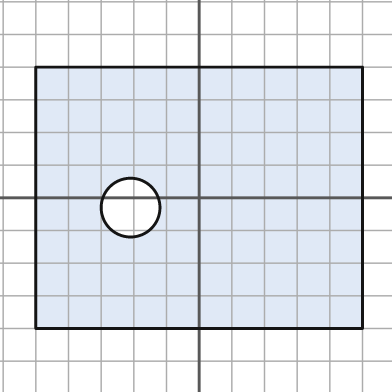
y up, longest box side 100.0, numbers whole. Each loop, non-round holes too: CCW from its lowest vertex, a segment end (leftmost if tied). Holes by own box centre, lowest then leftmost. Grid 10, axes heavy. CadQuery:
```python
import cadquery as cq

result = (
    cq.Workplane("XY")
    .moveTo(-50.0, -40.0)
    .lineTo(50.0, -40.0)
    .lineTo(50.0, 40.0)
    .lineTo(-50.0, 40.0)
    .close()
    .moveTo(-21.0, -3.0)
    .circle(9.0)
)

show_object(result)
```